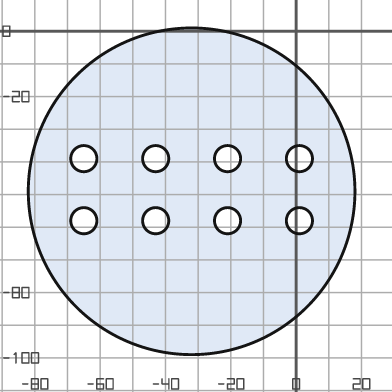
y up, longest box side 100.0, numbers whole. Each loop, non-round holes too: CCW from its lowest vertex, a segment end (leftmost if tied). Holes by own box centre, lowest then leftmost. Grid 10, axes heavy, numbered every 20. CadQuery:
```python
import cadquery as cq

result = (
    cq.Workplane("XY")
    .moveTo(-32.0, -49.0)
    .circle(50.0)
    .moveTo(-65.0, -58.0)
    .circle(4.0)
    .moveTo(-43.0, -58.0)
    .circle(4.0)
    .moveTo(-21.0, -58.0)
    .circle(4.0)
    .moveTo(1.0, -58.0)
    .circle(4.0)
    .moveTo(-65.0, -39.0)
    .circle(4.0)
    .moveTo(-43.0, -39.0)
    .circle(4.0)
    .moveTo(-21.0, -39.0)
    .circle(4.0)
    .moveTo(1.0, -39.0)
    .circle(4.0)
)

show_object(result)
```